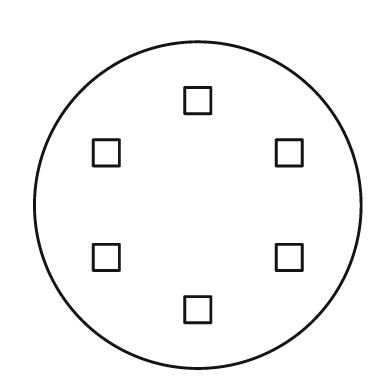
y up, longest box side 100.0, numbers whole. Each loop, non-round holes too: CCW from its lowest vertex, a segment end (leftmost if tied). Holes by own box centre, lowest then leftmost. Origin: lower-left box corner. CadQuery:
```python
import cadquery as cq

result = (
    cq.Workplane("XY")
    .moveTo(50.0, 50.0)
    .circle(50.0)
    .moveTo(46.0, 14.0)
    .lineTo(54.0, 14.0)
    .lineTo(54.0, 22.0)
    .lineTo(46.0, 22.0)
    .close()
    .moveTo(18.0, 30.0)
    .lineTo(26.0, 30.0)
    .lineTo(26.0, 38.0)
    .lineTo(18.0, 38.0)
    .close()
    .moveTo(74.0, 30.0)
    .lineTo(82.0, 30.0)
    .lineTo(82.0, 38.0)
    .lineTo(74.0, 38.0)
    .close()
    .moveTo(18.0, 62.0)
    .lineTo(26.0, 62.0)
    .lineTo(26.0, 70.0)
    .lineTo(18.0, 70.0)
    .close()
    .moveTo(74.0, 62.0)
    .lineTo(82.0, 62.0)
    .lineTo(82.0, 70.0)
    .lineTo(74.0, 70.0)
    .close()
    .moveTo(46.0, 78.0)
    .lineTo(54.0, 78.0)
    .lineTo(54.0, 86.0)
    .lineTo(46.0, 86.0)
    .close()
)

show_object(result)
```